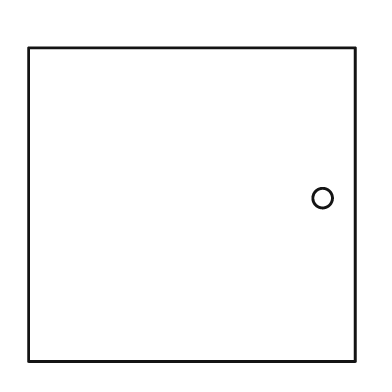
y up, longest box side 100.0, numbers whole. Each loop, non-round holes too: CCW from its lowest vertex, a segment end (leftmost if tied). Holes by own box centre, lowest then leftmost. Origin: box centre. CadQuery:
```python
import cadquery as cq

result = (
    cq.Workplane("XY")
    .moveTo(-50.0, -48.0)
    .lineTo(50.0, -48.0)
    .lineTo(50.0, 48.0)
    .lineTo(-50.0, 48.0)
    .close()
    .moveTo(40.0, 2.0)
    .circle(3.0)
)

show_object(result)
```